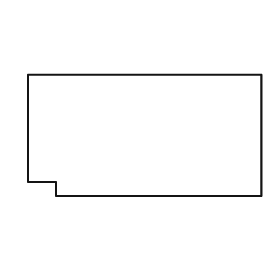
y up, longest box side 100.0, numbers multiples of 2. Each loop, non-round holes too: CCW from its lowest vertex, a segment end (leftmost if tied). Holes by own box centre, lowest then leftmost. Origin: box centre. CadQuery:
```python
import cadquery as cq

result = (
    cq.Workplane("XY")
    .moveTo(-38.0, -26.0)
    .lineTo(50.0, -26.0)
    .lineTo(50.0, 26.0)
    .lineTo(-50.0, 26.0)
    .lineTo(-50.0, -20.0)
    .lineTo(-38.0, -20.0)
    .close()
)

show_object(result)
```